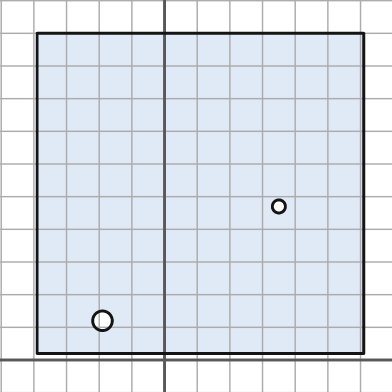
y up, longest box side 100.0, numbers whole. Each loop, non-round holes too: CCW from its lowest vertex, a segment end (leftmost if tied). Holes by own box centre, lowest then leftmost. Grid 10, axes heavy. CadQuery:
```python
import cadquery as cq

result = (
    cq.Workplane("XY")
    .moveTo(-39.0, 2.0)
    .lineTo(61.0, 2.0)
    .lineTo(61.0, 100.0)
    .lineTo(-39.0, 100.0)
    .close()
    .moveTo(-19.0, 12.0)
    .circle(3.0)
    .moveTo(35.0, 47.0)
    .circle(2.0)
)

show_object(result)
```